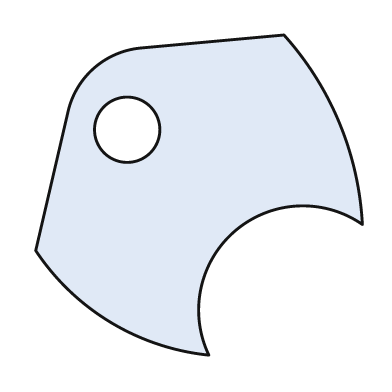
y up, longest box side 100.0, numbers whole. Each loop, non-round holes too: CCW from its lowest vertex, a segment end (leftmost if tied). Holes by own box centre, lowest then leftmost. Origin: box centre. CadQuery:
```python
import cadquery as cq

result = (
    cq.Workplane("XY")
    .moveTo(3.0, -49.0)
    .threePointArc((11.0, -11.0), (50.0, -9.0))
    .threePointArc((43.0, 22.0), (26.0, 49.0))
    .lineTo(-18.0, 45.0)
    .threePointArc((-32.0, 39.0), (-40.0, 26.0))
    .lineTo(-50.0, -17.0)
    .threePointArc((-27.0, -39.0), (3.0, -49.0))
    .close()
    .moveTo(-22.0, 20.0)
    .circle(10.0)
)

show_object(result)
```